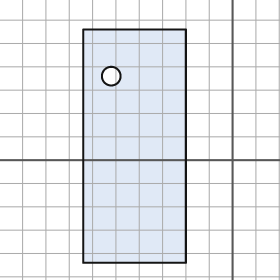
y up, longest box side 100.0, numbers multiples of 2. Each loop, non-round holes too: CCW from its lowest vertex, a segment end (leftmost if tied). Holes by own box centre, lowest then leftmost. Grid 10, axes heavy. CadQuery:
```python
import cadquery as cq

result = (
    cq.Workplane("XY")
    .moveTo(-64.0, -44.0)
    .lineTo(-20.0, -44.0)
    .lineTo(-20.0, 56.0)
    .lineTo(-64.0, 56.0)
    .close()
    .moveTo(-52.0, 36.0)
    .circle(4.0)
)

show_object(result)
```